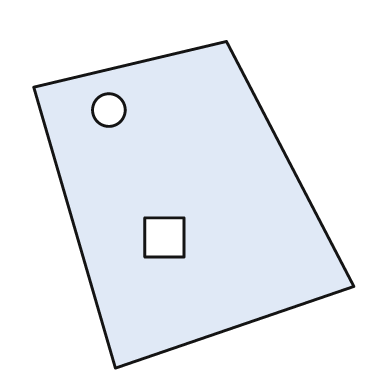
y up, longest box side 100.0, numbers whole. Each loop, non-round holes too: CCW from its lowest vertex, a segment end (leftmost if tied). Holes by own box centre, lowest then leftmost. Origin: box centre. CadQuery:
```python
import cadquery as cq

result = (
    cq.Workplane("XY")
    .moveTo(-24.0, -50.0)
    .lineTo(49.0, -25.0)
    .lineTo(10.0, 50.0)
    .lineTo(-49.0, 36.0)
    .close()
    .moveTo(-15.0, -16.0)
    .lineTo(-3.0, -16.0)
    .lineTo(-3.0, -4.0)
    .lineTo(-15.0, -4.0)
    .close()
    .moveTo(-26.0, 29.0)
    .circle(5.0)
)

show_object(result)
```